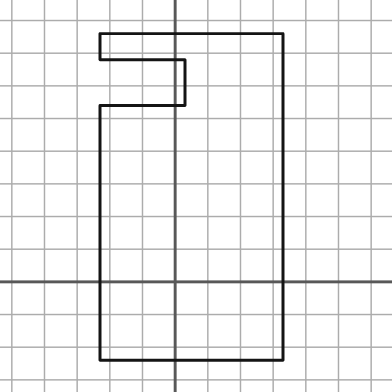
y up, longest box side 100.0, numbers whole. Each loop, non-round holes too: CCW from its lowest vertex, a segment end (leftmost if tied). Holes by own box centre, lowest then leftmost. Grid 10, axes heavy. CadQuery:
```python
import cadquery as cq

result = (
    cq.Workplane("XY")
    .moveTo(-23.0, -24.0)
    .lineTo(33.0, -24.0)
    .lineTo(33.0, 76.0)
    .lineTo(-23.0, 76.0)
    .lineTo(-23.0, 68.0)
    .lineTo(3.0, 68.0)
    .lineTo(3.0, 54.0)
    .lineTo(-23.0, 54.0)
    .close()
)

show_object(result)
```